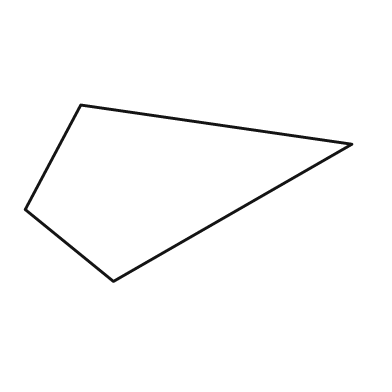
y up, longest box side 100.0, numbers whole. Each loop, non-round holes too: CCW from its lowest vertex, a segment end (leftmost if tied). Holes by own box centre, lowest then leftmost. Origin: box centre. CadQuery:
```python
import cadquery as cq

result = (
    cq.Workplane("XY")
    .moveTo(-23.0, -27.0)
    .lineTo(50.0, 15.0)
    .lineTo(-33.0, 27.0)
    .lineTo(-50.0, -5.0)
    .close()
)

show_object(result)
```